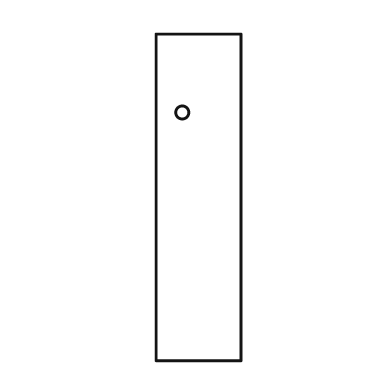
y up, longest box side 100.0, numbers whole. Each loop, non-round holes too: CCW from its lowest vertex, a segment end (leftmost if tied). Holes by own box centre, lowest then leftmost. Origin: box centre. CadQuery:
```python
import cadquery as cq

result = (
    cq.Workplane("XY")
    .moveTo(-13.0, -50.0)
    .lineTo(13.0, -50.0)
    .lineTo(13.0, 50.0)
    .lineTo(-13.0, 50.0)
    .close()
    .moveTo(-5.0, 26.0)
    .circle(2.0)
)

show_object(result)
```